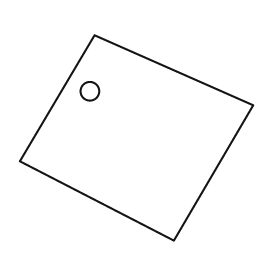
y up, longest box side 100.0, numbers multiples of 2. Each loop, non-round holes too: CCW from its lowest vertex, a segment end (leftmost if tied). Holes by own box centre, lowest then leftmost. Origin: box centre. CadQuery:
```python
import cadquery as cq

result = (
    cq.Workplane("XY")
    .moveTo(16.0, -44.0)
    .lineTo(50.0, 14.0)
    .lineTo(-18.0, 44.0)
    .lineTo(-50.0, -10.0)
    .close()
    .moveTo(-20.0, 20.0)
    .circle(4.0)
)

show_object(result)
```